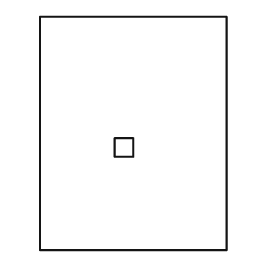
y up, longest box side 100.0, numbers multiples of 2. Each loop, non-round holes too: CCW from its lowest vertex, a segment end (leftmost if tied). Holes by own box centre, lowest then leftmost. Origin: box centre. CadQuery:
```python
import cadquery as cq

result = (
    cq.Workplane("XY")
    .moveTo(-40.0, -50.0)
    .lineTo(40.0, -50.0)
    .lineTo(40.0, 50.0)
    .lineTo(-40.0, 50.0)
    .close()
    .moveTo(-8.0, -10.0)
    .lineTo(0.0, -10.0)
    .lineTo(0.0, -2.0)
    .lineTo(-8.0, -2.0)
    .close()
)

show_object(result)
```